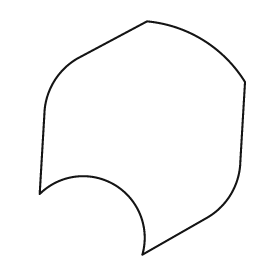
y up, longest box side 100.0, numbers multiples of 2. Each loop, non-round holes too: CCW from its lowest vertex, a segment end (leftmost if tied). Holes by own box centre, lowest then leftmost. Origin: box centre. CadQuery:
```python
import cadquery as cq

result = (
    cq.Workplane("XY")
    .moveTo(0.0, -50.0)
    .lineTo(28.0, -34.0)
    .threePointArc((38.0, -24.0), (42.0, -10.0))
    .lineTo(44.0, 24.0)
    .threePointArc((26.0, 42.0), (2.0, 50.0))
    .lineTo(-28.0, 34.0)
    .threePointArc((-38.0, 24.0), (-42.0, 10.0))
    .lineTo(-44.0, -24.0)
    .threePointArc((-12.0, -20.0), (0.0, -50.0))
    .close()
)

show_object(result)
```